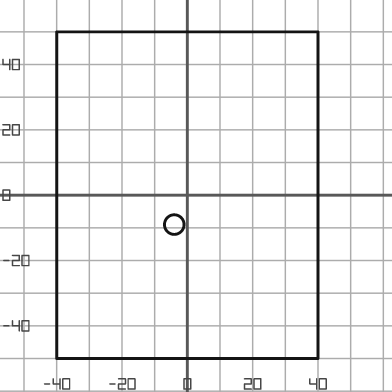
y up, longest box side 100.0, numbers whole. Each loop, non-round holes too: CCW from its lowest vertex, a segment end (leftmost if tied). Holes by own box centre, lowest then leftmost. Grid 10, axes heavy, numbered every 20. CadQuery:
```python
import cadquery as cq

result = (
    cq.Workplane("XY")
    .moveTo(-40.0, -50.0)
    .lineTo(40.0, -50.0)
    .lineTo(40.0, 50.0)
    .lineTo(-40.0, 50.0)
    .close()
    .moveTo(-4.0, -9.0)
    .circle(3.0)
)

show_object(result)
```